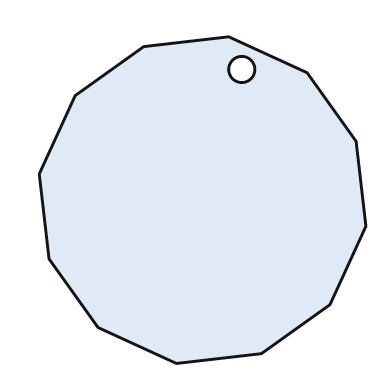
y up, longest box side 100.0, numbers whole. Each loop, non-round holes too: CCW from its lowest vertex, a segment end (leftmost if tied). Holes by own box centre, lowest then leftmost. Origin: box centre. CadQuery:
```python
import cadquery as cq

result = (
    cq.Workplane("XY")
    .moveTo(-8.0, -50.0)
    .lineTo(18.0, -47.0)
    .lineTo(39.0, -32.0)
    .lineTo(50.0, -8.0)
    .lineTo(47.0, 18.0)
    .lineTo(32.0, 39.0)
    .lineTo(8.0, 50.0)
    .lineTo(-18.0, 47.0)
    .lineTo(-39.0, 32.0)
    .lineTo(-50.0, 8.0)
    .lineTo(-47.0, -18.0)
    .lineTo(-32.0, -39.0)
    .close()
    .moveTo(12.0, 40.0)
    .circle(4.0)
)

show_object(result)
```